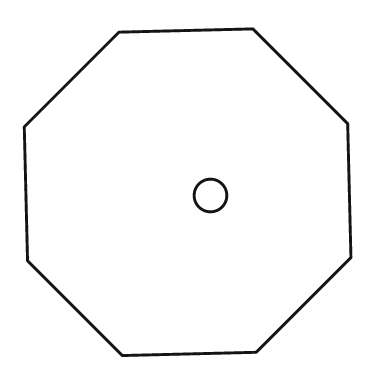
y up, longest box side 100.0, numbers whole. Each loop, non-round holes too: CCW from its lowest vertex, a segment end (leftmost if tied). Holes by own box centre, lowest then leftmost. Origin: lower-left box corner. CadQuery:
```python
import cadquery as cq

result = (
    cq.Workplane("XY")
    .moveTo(30.0, 0.0)
    .lineTo(71.0, 1.0)
    .lineTo(100.0, 30.0)
    .lineTo(99.0, 71.0)
    .lineTo(70.0, 100.0)
    .lineTo(29.0, 99.0)
    .lineTo(0.0, 70.0)
    .lineTo(1.0, 29.0)
    .close()
    .moveTo(57.0, 49.0)
    .circle(5.0)
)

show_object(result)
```